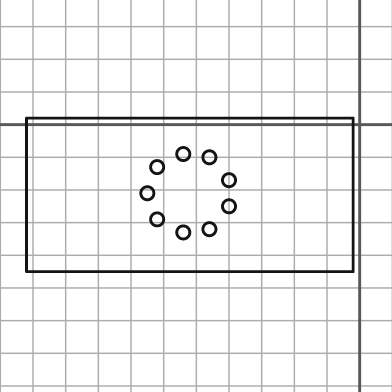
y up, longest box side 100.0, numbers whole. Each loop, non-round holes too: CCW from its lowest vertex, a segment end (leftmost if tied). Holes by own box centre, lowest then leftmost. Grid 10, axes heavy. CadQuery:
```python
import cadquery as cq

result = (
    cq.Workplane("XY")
    .moveTo(-102.0, -45.0)
    .lineTo(-2.0, -45.0)
    .lineTo(-2.0, 2.0)
    .lineTo(-102.0, 2.0)
    .close()
    .moveTo(-54.0, -33.0)
    .circle(2.0)
    .moveTo(-46.0, -32.0)
    .circle(2.0)
    .moveTo(-62.0, -29.0)
    .circle(2.0)
    .moveTo(-40.0, -25.0)
    .circle(2.0)
    .moveTo(-65.0, -21.0)
    .circle(2.0)
    .moveTo(-40.0, -17.0)
    .circle(2.0)
    .moveTo(-62.0, -13.0)
    .circle(2.0)
    .moveTo(-46.0, -10.0)
    .circle(2.0)
    .moveTo(-54.0, -9.0)
    .circle(2.0)
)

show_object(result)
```